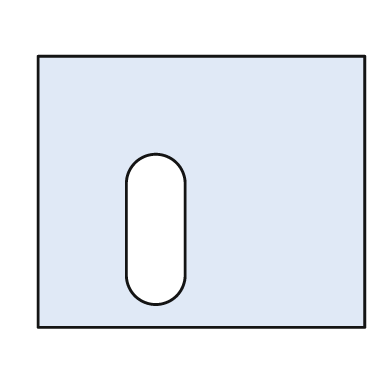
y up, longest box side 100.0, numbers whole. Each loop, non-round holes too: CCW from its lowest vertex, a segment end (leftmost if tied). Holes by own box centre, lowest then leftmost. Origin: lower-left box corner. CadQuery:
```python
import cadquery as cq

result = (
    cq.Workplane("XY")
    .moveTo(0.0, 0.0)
    .lineTo(100.0, 0.0)
    .lineTo(100.0, 83.0)
    .lineTo(0.0, 83.0)
    .close()
    .moveTo(27.0, 16.0)
    .threePointArc((36.0, 7.0), (45.0, 16.0))
    .lineTo(45.0, 44.0)
    .threePointArc((36.0, 53.0), (27.0, 44.0))
    .close()
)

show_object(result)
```